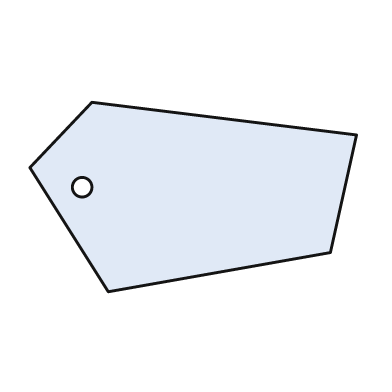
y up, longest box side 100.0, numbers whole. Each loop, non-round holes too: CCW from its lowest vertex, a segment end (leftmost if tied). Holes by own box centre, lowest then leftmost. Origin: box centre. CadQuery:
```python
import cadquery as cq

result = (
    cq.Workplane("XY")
    .moveTo(-26.0, -29.0)
    .lineTo(42.0, -17.0)
    .lineTo(50.0, 19.0)
    .lineTo(-31.0, 29.0)
    .lineTo(-50.0, 9.0)
    .close()
    .moveTo(-34.0, 3.0)
    .circle(3.0)
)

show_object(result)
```